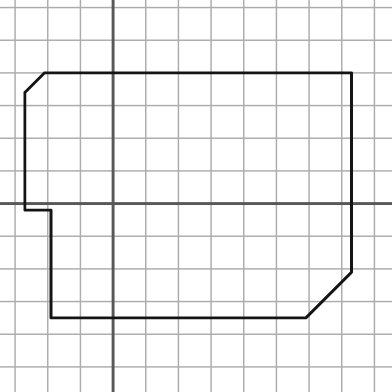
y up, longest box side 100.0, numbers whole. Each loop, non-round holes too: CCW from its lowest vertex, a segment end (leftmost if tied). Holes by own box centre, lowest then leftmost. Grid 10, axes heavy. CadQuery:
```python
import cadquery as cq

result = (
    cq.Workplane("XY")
    .moveTo(-19.0, -35.0)
    .lineTo(59.0, -35.0)
    .lineTo(73.0, -21.0)
    .lineTo(73.0, 40.0)
    .lineTo(-21.0, 40.0)
    .lineTo(-27.0, 34.0)
    .lineTo(-27.0, -2.0)
    .lineTo(-19.0, -2.0)
    .close()
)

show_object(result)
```